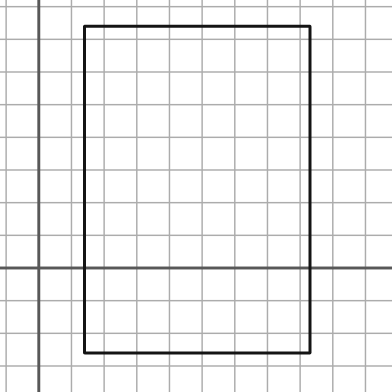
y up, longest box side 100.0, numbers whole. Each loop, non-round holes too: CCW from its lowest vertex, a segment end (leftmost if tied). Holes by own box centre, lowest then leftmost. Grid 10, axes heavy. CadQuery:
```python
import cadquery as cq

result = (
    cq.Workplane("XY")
    .moveTo(14.0, -26.0)
    .lineTo(83.0, -26.0)
    .lineTo(83.0, 74.0)
    .lineTo(14.0, 74.0)
    .close()
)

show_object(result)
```